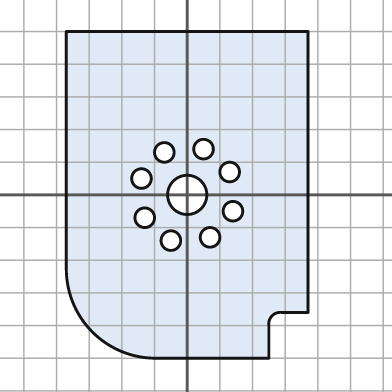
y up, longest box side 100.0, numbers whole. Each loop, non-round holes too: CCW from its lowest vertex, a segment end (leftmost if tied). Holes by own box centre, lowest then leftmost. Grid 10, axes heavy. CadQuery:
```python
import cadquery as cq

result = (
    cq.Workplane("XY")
    .moveTo(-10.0, -50.0)
    .lineTo(25.0, -50.0)
    .lineTo(25.0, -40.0)
    .threePointArc((26.0, -37.0), (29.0, -36.0))
    .lineTo(37.0, -36.0)
    .lineTo(37.0, 50.0)
    .lineTo(-37.0, 50.0)
    .lineTo(-37.0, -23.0)
    .threePointArc((-29.0, -42.0), (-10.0, -50.0))
    .close()
    .moveTo(-5.0, -14.0)
    .circle(3.0)
    .moveTo(7.0, -13.0)
    .circle(3.0)
    .moveTo(-13.0, -7.0)
    .circle(3.0)
    .moveTo(14.0, -5.0)
    .circle(3.0)
    .moveTo(0.0, 0.0)
    .circle(6.0)
    .moveTo(-14.0, 5.0)
    .circle(3.0)
    .moveTo(13.0, 7.0)
    .circle(3.0)
    .moveTo(-7.0, 13.0)
    .circle(3.0)
    .moveTo(5.0, 14.0)
    .circle(3.0)
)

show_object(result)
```